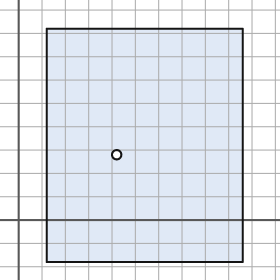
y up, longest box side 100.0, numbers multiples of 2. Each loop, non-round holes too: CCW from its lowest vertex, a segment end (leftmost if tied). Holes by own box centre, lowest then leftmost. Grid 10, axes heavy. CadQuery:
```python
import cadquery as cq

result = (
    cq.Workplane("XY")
    .moveTo(12.0, -18.0)
    .lineTo(96.0, -18.0)
    .lineTo(96.0, 82.0)
    .lineTo(12.0, 82.0)
    .close()
    .moveTo(42.0, 28.0)
    .circle(2.0)
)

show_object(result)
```